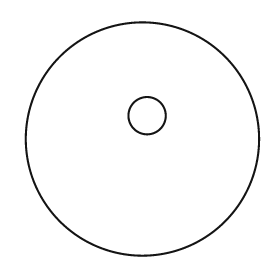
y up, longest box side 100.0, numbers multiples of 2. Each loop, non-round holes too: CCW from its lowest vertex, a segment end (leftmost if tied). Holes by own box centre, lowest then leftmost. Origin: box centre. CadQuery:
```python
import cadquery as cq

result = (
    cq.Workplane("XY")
    .moveTo(0.0, 0.0)
    .circle(50.0)
    .moveTo(2.0, 10.0)
    .circle(8.0)
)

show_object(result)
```